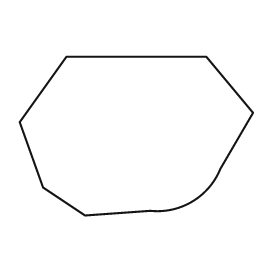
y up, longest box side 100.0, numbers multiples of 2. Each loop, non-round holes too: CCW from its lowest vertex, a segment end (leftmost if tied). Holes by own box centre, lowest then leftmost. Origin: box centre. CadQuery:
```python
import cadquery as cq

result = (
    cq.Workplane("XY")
    .moveTo(-22.0, -34.0)
    .lineTo(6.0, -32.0)
    .threePointArc((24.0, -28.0), (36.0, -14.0))
    .lineTo(50.0, 10.0)
    .lineTo(30.0, 34.0)
    .lineTo(-30.0, 34.0)
    .lineTo(-50.0, 6.0)
    .lineTo(-40.0, -22.0)
    .close()
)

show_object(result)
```